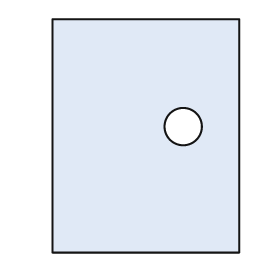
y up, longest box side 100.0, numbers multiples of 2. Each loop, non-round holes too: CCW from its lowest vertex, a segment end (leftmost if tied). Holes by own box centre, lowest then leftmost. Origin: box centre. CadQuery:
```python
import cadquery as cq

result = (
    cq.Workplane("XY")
    .moveTo(-40.0, -50.0)
    .lineTo(40.0, -50.0)
    .lineTo(40.0, 50.0)
    .lineTo(-40.0, 50.0)
    .close()
    .moveTo(16.0, 4.0)
    .circle(8.0)
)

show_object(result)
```